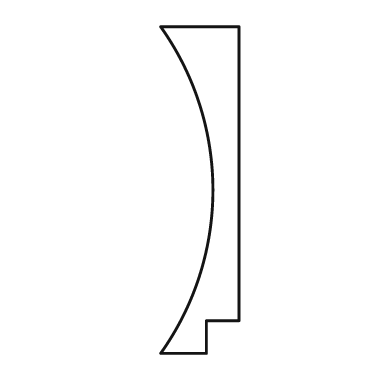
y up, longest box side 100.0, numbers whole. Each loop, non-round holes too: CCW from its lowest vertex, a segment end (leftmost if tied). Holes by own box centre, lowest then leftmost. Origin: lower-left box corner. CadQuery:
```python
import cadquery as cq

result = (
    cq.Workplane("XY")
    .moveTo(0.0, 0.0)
    .lineTo(14.0, 0.0)
    .lineTo(14.0, 10.0)
    .lineTo(24.0, 10.0)
    .lineTo(24.0, 100.0)
    .lineTo(0.0, 100.0)
    .threePointArc((16.0, 50.0), (0.0, 0.0))
    .close()
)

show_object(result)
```